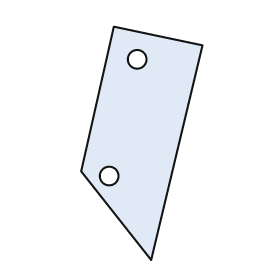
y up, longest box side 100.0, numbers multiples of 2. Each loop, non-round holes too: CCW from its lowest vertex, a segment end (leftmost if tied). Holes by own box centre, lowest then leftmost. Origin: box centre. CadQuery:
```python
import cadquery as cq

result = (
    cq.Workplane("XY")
    .moveTo(4.0, -50.0)
    .lineTo(26.0, 42.0)
    .lineTo(-12.0, 50.0)
    .lineTo(-26.0, -12.0)
    .close()
    .moveTo(-14.0, -14.0)
    .circle(4.0)
    .moveTo(-2.0, 36.0)
    .circle(4.0)
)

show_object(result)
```